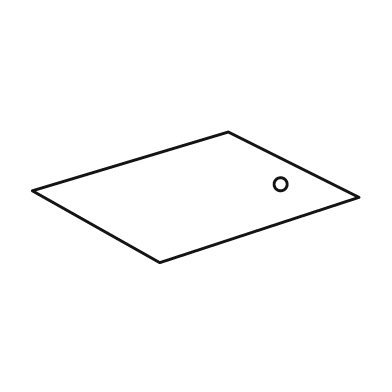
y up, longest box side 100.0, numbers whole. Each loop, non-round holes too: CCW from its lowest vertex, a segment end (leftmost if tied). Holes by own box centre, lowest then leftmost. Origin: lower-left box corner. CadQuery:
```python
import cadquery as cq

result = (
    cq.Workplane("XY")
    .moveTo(39.0, 0.0)
    .lineTo(100.0, 20.0)
    .lineTo(60.0, 40.0)
    .lineTo(0.0, 22.0)
    .close()
    .moveTo(76.0, 24.0)
    .circle(2.0)
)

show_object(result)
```